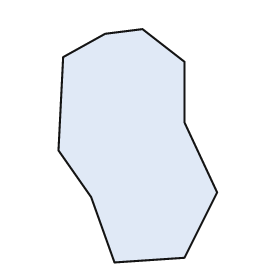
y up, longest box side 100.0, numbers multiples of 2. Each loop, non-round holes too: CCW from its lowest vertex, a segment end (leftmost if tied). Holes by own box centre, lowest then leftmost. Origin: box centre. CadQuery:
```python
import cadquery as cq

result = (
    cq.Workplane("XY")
    .moveTo(-10.0, -50.0)
    .lineTo(20.0, -48.0)
    .lineTo(34.0, -20.0)
    .lineTo(20.0, 10.0)
    .lineTo(20.0, 36.0)
    .lineTo(2.0, 50.0)
    .lineTo(-14.0, 48.0)
    .lineTo(-32.0, 38.0)
    .lineTo(-34.0, -2.0)
    .lineTo(-20.0, -22.0)
    .close()
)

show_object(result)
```